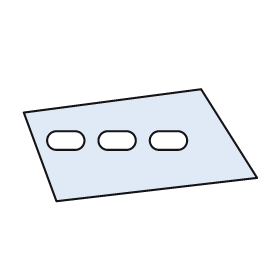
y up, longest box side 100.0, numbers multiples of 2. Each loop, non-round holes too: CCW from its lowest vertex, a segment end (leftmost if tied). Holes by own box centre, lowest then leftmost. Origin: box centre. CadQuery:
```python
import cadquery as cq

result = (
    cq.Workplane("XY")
    .moveTo(-36.0, -24.0)
    .lineTo(50.0, -14.0)
    .lineTo(26.0, 24.0)
    .lineTo(-50.0, 14.0)
    .close()
    .moveTo(-36.0, -2.0)
    .lineTo(-28.0, -2.0)
    .threePointArc((-24.0, 2.0), (-28.0, 6.0))
    .lineTo(-36.0, 6.0)
    .threePointArc((-40.0, 2.0), (-36.0, -2.0))
    .close()
    .moveTo(-14.0, -2.0)
    .lineTo(-6.0, -2.0)
    .threePointArc((-2.0, 2.0), (-6.0, 6.0))
    .lineTo(-14.0, 6.0)
    .threePointArc((-18.0, 2.0), (-14.0, -2.0))
    .close()
    .moveTo(8.0, -2.0)
    .lineTo(16.0, -2.0)
    .threePointArc((20.0, 2.0), (16.0, 6.0))
    .lineTo(8.0, 6.0)
    .threePointArc((4.0, 2.0), (8.0, -2.0))
    .close()
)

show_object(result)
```